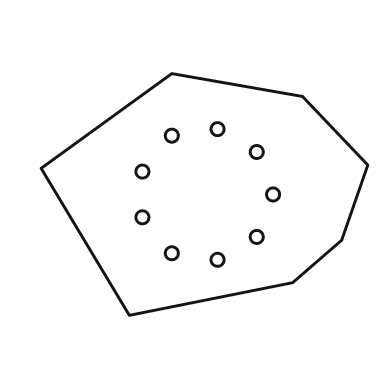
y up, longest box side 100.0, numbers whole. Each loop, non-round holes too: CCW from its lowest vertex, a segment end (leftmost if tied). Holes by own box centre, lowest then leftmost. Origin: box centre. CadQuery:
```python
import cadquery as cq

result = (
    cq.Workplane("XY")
    .moveTo(-23.0, -37.0)
    .lineTo(27.0, -27.0)
    .lineTo(42.0, -14.0)
    .lineTo(50.0, 9.0)
    .lineTo(30.0, 30.0)
    .lineTo(-10.0, 37.0)
    .lineTo(-50.0, 8.0)
    .close()
    .moveTo(4.0, -20.0)
    .circle(2.0)
    .moveTo(-10.0, -18.0)
    .circle(2.0)
    .moveTo(16.0, -13.0)
    .circle(2.0)
    .moveTo(-19.0, -7.0)
    .circle(2.0)
    .moveTo(21.0, 0.0)
    .circle(2.0)
    .moveTo(-19.0, 7.0)
    .circle(2.0)
    .moveTo(16.0, 13.0)
    .circle(2.0)
    .moveTo(-10.0, 18.0)
    .circle(2.0)
    .moveTo(4.0, 20.0)
    .circle(2.0)
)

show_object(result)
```